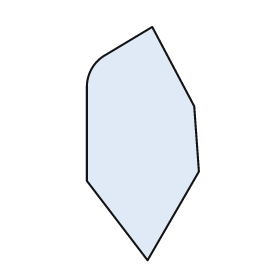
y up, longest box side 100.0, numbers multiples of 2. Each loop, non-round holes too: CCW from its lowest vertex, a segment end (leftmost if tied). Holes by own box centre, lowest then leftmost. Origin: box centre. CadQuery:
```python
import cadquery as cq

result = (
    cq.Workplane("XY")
    .moveTo(2.0, -50.0)
    .lineTo(24.0, -12.0)
    .lineTo(22.0, 16.0)
    .lineTo(4.0, 50.0)
    .lineTo(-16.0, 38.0)
    .threePointArc((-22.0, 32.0), (-24.0, 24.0))
    .lineTo(-24.0, -16.0)
    .close()
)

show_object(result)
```